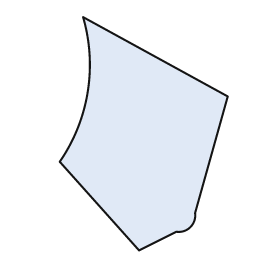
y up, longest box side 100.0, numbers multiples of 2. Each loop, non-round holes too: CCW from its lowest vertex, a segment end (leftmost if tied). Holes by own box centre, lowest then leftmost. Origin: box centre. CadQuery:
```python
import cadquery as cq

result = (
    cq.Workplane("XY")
    .moveTo(-2.0, -50.0)
    .lineTo(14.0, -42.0)
    .threePointArc((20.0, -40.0), (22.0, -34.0))
    .lineTo(36.0, 16.0)
    .lineTo(-26.0, 50.0)
    .threePointArc((-24.0, 18.0), (-36.0, -12.0))
    .close()
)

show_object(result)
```